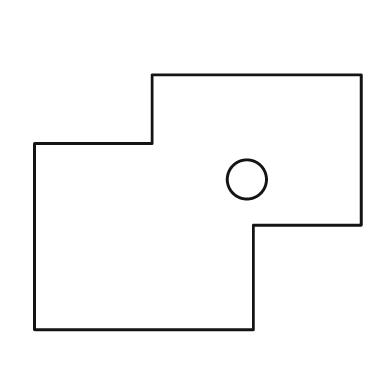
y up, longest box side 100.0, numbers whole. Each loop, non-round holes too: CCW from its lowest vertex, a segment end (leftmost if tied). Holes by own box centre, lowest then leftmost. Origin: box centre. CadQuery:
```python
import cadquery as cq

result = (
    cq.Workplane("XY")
    .moveTo(-50.0, -39.0)
    .lineTo(17.0, -39.0)
    .lineTo(17.0, -7.0)
    .lineTo(50.0, -7.0)
    .lineTo(50.0, 39.0)
    .lineTo(-14.0, 39.0)
    .lineTo(-14.0, 18.0)
    .lineTo(-50.0, 18.0)
    .close()
    .moveTo(15.0, 7.0)
    .circle(6.0)
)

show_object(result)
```